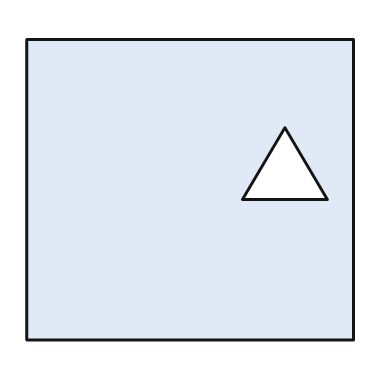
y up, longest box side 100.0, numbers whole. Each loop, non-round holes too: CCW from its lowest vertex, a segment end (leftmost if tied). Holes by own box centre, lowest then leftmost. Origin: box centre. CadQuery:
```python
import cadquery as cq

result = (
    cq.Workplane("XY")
    .moveTo(-50.0, -46.0)
    .lineTo(50.0, -46.0)
    .lineTo(50.0, 46.0)
    .lineTo(-50.0, 46.0)
    .close()
    .moveTo(16.0, -3.0)
    .lineTo(42.0, -3.0)
    .lineTo(29.0, 19.0)
    .close()
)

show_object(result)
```